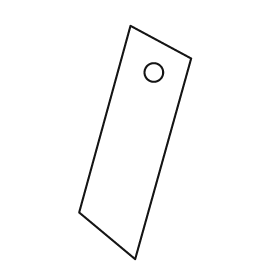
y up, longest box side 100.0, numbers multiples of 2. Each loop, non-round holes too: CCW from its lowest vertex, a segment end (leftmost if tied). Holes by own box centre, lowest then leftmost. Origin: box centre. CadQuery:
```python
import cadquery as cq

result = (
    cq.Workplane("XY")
    .moveTo(0.0, -50.0)
    .lineTo(24.0, 36.0)
    .lineTo(-2.0, 50.0)
    .lineTo(-24.0, -30.0)
    .close()
    .moveTo(8.0, 30.0)
    .circle(4.0)
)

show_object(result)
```